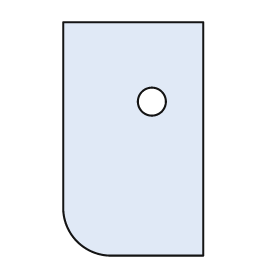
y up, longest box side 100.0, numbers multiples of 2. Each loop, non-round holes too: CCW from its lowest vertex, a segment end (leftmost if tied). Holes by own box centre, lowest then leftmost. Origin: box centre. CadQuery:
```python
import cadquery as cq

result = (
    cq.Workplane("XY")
    .moveTo(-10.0, -50.0)
    .lineTo(30.0, -50.0)
    .lineTo(30.0, 50.0)
    .lineTo(-30.0, 50.0)
    .lineTo(-30.0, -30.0)
    .threePointArc((-24.0, -44.0), (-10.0, -50.0))
    .close()
    .moveTo(8.0, 16.0)
    .circle(6.0)
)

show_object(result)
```